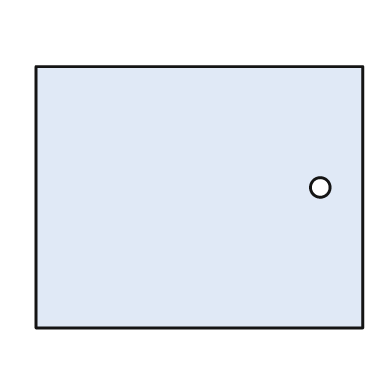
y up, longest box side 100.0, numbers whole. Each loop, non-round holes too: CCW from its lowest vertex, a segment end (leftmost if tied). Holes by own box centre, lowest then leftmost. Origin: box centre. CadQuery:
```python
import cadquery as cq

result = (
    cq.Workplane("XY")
    .moveTo(-50.0, -40.0)
    .lineTo(50.0, -40.0)
    .lineTo(50.0, 40.0)
    .lineTo(-50.0, 40.0)
    .close()
    .moveTo(37.0, 3.0)
    .circle(3.0)
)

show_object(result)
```